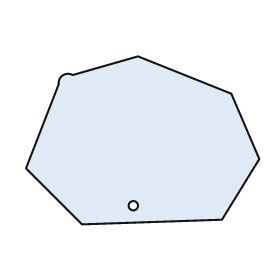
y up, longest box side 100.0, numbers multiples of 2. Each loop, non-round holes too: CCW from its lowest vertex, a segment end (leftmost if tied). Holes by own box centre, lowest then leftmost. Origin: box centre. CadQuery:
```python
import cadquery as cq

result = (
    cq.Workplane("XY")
    .moveTo(-26.0, -36.0)
    .lineTo(34.0, -34.0)
    .lineTo(50.0, -8.0)
    .lineTo(38.0, 20.0)
    .lineTo(-2.0, 36.0)
    .lineTo(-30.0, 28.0)
    .threePointArc((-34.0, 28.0), (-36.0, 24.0))
    .lineTo(-50.0, -12.0)
    .close()
    .moveTo(-4.0, -28.0)
    .circle(2.0)
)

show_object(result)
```